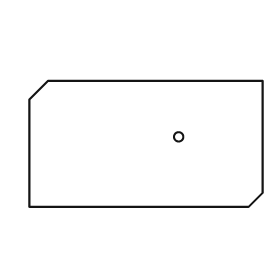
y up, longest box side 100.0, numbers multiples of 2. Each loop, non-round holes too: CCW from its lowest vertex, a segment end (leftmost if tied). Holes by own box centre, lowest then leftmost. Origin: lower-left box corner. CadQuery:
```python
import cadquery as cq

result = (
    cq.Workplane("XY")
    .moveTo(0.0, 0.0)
    .lineTo(94.0, 0.0)
    .lineTo(100.0, 6.0)
    .lineTo(100.0, 54.0)
    .lineTo(8.0, 54.0)
    .lineTo(0.0, 46.0)
    .close()
    .moveTo(64.0, 30.0)
    .circle(2.0)
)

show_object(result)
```